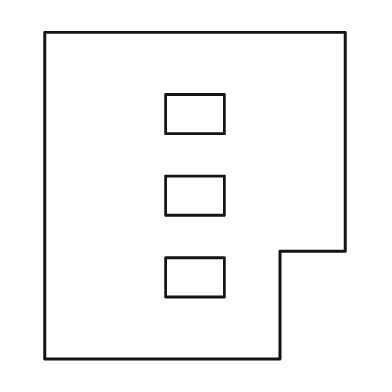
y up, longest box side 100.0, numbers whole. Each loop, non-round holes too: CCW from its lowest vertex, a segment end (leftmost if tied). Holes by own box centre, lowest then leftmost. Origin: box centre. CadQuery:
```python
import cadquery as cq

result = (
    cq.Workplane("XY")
    .moveTo(-46.0, -50.0)
    .lineTo(26.0, -50.0)
    .lineTo(26.0, -17.0)
    .lineTo(46.0, -17.0)
    .lineTo(46.0, 50.0)
    .lineTo(-46.0, 50.0)
    .close()
    .moveTo(-9.0, -31.0)
    .lineTo(9.0, -31.0)
    .lineTo(9.0, -19.0)
    .lineTo(-9.0, -19.0)
    .close()
    .moveTo(-9.0, -6.0)
    .lineTo(9.0, -6.0)
    .lineTo(9.0, 6.0)
    .lineTo(-9.0, 6.0)
    .close()
    .moveTo(-9.0, 19.0)
    .lineTo(9.0, 19.0)
    .lineTo(9.0, 31.0)
    .lineTo(-9.0, 31.0)
    .close()
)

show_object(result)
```